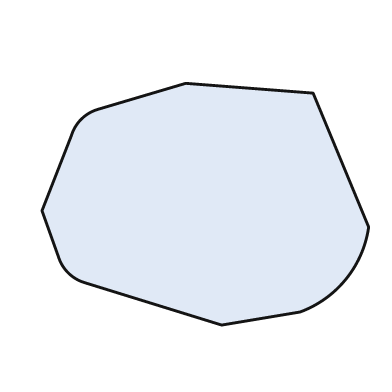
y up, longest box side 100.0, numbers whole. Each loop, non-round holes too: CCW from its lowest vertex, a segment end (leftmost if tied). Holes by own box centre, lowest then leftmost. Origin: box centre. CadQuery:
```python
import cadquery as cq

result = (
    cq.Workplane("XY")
    .moveTo(5.0, -37.0)
    .lineTo(29.0, -33.0)
    .threePointArc((43.0, -23.0), (50.0, -7.0))
    .lineTo(33.0, 34.0)
    .lineTo(-6.0, 37.0)
    .lineTo(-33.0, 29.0)
    .threePointArc((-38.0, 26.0), (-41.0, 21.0))
    .lineTo(-50.0, -2.0)
    .lineTo(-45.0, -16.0)
    .threePointArc((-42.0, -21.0), (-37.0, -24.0))
    .close()
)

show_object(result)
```